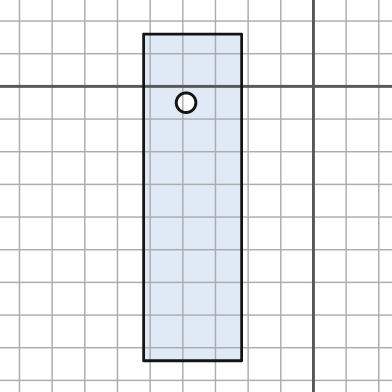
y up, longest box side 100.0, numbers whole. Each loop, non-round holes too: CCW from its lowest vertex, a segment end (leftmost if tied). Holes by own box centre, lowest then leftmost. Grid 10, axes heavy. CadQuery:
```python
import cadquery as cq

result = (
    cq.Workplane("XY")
    .moveTo(-52.0, -84.0)
    .lineTo(-22.0, -84.0)
    .lineTo(-22.0, 16.0)
    .lineTo(-52.0, 16.0)
    .close()
    .moveTo(-39.0, -5.0)
    .circle(3.0)
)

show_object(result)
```